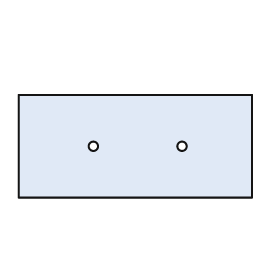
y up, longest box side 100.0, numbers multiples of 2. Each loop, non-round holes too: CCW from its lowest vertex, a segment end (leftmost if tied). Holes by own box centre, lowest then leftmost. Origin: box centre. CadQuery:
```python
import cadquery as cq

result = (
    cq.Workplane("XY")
    .moveTo(-50.0, -22.0)
    .lineTo(50.0, -22.0)
    .lineTo(50.0, 22.0)
    .lineTo(-50.0, 22.0)
    .close()
    .moveTo(-18.0, 0.0)
    .circle(2.0)
    .moveTo(20.0, 0.0)
    .circle(2.0)
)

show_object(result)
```